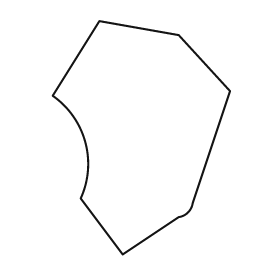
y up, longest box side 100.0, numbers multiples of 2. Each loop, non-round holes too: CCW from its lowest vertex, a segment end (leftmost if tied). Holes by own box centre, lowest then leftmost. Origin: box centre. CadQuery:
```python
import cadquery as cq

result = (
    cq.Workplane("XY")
    .moveTo(-8.0, -50.0)
    .lineTo(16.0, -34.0)
    .threePointArc((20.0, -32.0), (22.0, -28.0))
    .lineTo(38.0, 20.0)
    .lineTo(16.0, 44.0)
    .lineTo(-18.0, 50.0)
    .lineTo(-38.0, 18.0)
    .threePointArc((-24.0, -2.0), (-26.0, -26.0))
    .close()
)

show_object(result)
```